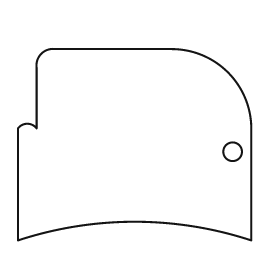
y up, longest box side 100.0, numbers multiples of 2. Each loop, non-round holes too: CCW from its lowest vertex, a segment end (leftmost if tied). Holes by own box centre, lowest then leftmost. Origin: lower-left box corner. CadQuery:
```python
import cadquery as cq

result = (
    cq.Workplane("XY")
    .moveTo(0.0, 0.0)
    .threePointArc((50.0, 8.0), (100.0, 0.0))
    .lineTo(100.0, 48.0)
    .threePointArc((90.0, 72.0), (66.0, 82.0))
    .lineTo(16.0, 82.0)
    .threePointArc((10.0, 80.0), (8.0, 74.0))
    .lineTo(8.0, 48.0)
    .threePointArc((4.0, 50.0), (0.0, 48.0))
    .close()
    .moveTo(92.0, 38.0)
    .circle(4.0)
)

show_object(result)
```